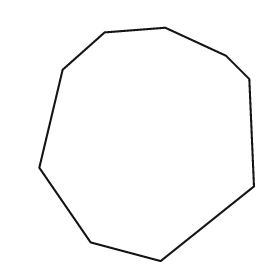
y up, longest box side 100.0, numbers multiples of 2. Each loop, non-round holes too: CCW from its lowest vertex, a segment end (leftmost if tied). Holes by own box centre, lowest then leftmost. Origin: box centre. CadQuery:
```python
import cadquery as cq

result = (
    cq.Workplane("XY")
    .moveTo(6.0, -50.0)
    .lineTo(46.0, -18.0)
    .lineTo(44.0, 28.0)
    .lineTo(34.0, 38.0)
    .lineTo(8.0, 50.0)
    .lineTo(-18.0, 48.0)
    .lineTo(-36.0, 32.0)
    .lineTo(-46.0, -10.0)
    .lineTo(-24.0, -42.0)
    .close()
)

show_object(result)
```